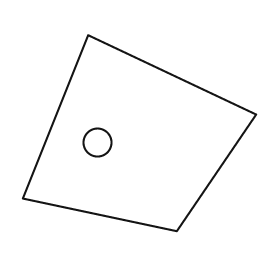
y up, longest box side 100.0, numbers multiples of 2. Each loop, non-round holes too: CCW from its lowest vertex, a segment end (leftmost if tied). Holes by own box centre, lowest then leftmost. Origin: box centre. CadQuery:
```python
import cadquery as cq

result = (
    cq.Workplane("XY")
    .moveTo(16.0, -42.0)
    .lineTo(50.0, 8.0)
    .lineTo(-22.0, 42.0)
    .lineTo(-50.0, -28.0)
    .close()
    .moveTo(-18.0, -4.0)
    .circle(6.0)
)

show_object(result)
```